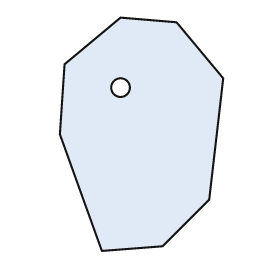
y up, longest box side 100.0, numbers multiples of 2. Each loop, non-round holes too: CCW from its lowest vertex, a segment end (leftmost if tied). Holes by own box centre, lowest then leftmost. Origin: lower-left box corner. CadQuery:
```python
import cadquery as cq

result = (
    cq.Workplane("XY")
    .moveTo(18.0, 0.0)
    .lineTo(44.0, 2.0)
    .lineTo(64.0, 22.0)
    .lineTo(70.0, 74.0)
    .lineTo(50.0, 98.0)
    .lineTo(26.0, 100.0)
    .lineTo(2.0, 80.0)
    .lineTo(0.0, 50.0)
    .close()
    .moveTo(26.0, 70.0)
    .circle(4.0)
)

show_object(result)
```